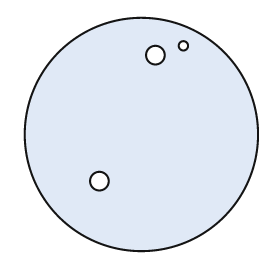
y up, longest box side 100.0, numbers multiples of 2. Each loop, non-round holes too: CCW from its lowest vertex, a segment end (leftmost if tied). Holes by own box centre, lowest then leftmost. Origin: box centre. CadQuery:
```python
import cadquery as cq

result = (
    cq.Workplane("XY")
    .moveTo(0.0, 0.0)
    .circle(50.0)
    .moveTo(-18.0, -20.0)
    .circle(4.0)
    .moveTo(6.0, 34.0)
    .circle(4.0)
    .moveTo(18.0, 38.0)
    .circle(2.0)
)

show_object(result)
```